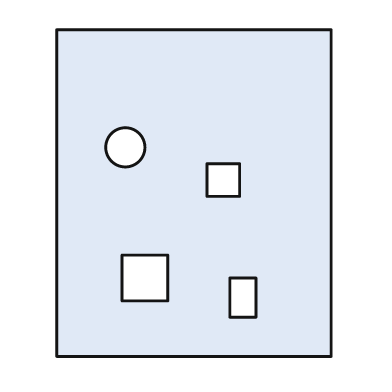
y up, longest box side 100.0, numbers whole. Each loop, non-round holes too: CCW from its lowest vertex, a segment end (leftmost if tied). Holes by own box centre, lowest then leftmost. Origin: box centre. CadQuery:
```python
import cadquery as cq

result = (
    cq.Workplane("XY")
    .moveTo(-42.0, -50.0)
    .lineTo(42.0, -50.0)
    .lineTo(42.0, 50.0)
    .lineTo(-42.0, 50.0)
    .close()
    .moveTo(11.0, -38.0)
    .lineTo(19.0, -38.0)
    .lineTo(19.0, -26.0)
    .lineTo(11.0, -26.0)
    .close()
    .moveTo(-22.0, -33.0)
    .lineTo(-8.0, -33.0)
    .lineTo(-8.0, -19.0)
    .lineTo(-22.0, -19.0)
    .close()
    .moveTo(4.0, -1.0)
    .lineTo(14.0, -1.0)
    .lineTo(14.0, 9.0)
    .lineTo(4.0, 9.0)
    .close()
    .moveTo(-21.0, 14.0)
    .circle(6.0)
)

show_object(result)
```